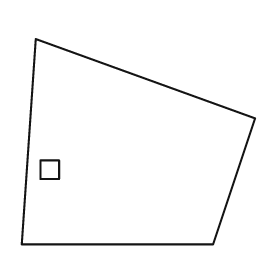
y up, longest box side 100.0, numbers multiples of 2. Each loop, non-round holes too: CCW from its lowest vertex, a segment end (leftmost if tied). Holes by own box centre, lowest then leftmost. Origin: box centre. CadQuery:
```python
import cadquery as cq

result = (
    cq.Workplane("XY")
    .moveTo(-50.0, -44.0)
    .lineTo(32.0, -44.0)
    .lineTo(50.0, 10.0)
    .lineTo(-44.0, 44.0)
    .close()
    .moveTo(-42.0, -16.0)
    .lineTo(-34.0, -16.0)
    .lineTo(-34.0, -8.0)
    .lineTo(-42.0, -8.0)
    .close()
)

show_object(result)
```